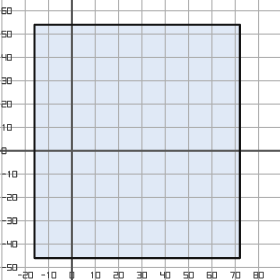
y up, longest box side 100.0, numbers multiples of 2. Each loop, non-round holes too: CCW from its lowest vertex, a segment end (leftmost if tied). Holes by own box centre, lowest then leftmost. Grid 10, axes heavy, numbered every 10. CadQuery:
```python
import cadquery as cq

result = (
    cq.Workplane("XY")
    .moveTo(-16.0, -46.0)
    .lineTo(72.0, -46.0)
    .lineTo(72.0, 54.0)
    .lineTo(-16.0, 54.0)
    .close()
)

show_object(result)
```